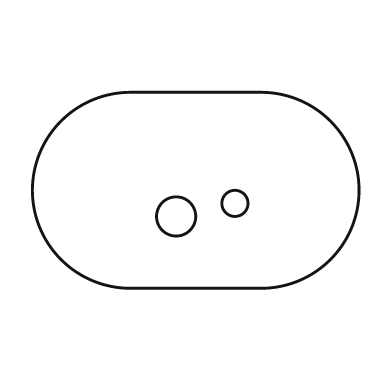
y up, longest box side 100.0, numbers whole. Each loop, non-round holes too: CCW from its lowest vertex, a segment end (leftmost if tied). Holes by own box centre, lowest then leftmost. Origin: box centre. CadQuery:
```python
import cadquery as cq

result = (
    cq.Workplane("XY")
    .moveTo(-20.0, -30.0)
    .lineTo(20.0, -30.0)
    .threePointArc((50.0, 0.0), (20.0, 30.0))
    .lineTo(-20.0, 30.0)
    .threePointArc((-50.0, 0.0), (-20.0, -30.0))
    .close()
    .moveTo(-6.0, -8.0)
    .circle(6.0)
    .moveTo(12.0, -4.0)
    .circle(4.0)
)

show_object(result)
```